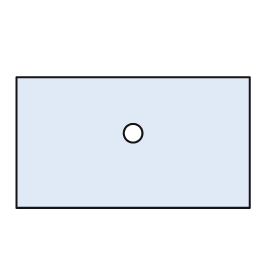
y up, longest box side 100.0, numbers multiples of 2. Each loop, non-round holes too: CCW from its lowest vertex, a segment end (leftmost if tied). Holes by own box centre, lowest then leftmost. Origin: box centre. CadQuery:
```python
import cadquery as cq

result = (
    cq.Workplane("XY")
    .moveTo(-50.0, -28.0)
    .lineTo(50.0, -28.0)
    .lineTo(50.0, 28.0)
    .lineTo(-50.0, 28.0)
    .close()
    .moveTo(0.0, 4.0)
    .circle(4.0)
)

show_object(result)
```